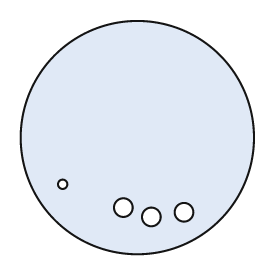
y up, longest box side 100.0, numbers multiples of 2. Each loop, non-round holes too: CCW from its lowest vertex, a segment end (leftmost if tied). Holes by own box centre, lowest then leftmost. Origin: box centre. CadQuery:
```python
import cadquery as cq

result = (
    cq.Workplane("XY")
    .moveTo(0.0, 0.0)
    .circle(50.0)
    .moveTo(6.0, -34.0)
    .circle(4.0)
    .moveTo(20.0, -32.0)
    .circle(4.0)
    .moveTo(-6.0, -30.0)
    .circle(4.0)
    .moveTo(-32.0, -20.0)
    .circle(2.0)
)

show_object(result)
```